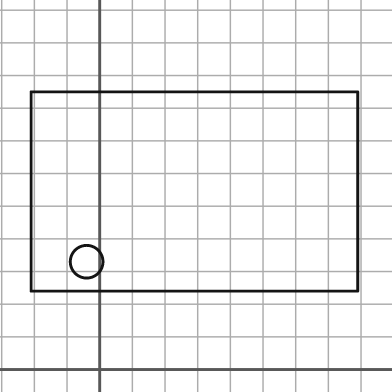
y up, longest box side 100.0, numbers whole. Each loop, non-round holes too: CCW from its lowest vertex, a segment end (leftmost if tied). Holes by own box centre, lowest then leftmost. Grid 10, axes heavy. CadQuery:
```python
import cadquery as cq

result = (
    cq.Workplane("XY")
    .moveTo(-21.0, 24.0)
    .lineTo(79.0, 24.0)
    .lineTo(79.0, 85.0)
    .lineTo(-21.0, 85.0)
    .close()
    .moveTo(-4.0, 33.0)
    .circle(5.0)
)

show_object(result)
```